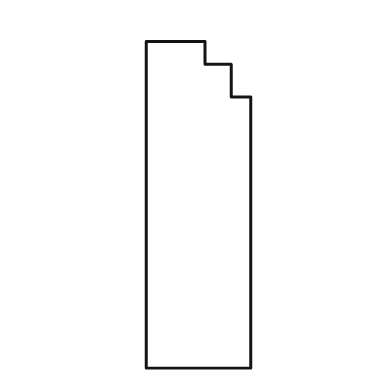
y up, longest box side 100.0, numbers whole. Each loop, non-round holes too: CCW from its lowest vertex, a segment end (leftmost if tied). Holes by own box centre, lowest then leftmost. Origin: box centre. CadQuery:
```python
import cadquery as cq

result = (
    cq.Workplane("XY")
    .moveTo(-16.0, -50.0)
    .lineTo(16.0, -50.0)
    .lineTo(16.0, 33.0)
    .lineTo(10.0, 33.0)
    .lineTo(10.0, 43.0)
    .lineTo(2.0, 43.0)
    .lineTo(2.0, 50.0)
    .lineTo(-16.0, 50.0)
    .close()
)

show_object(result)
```